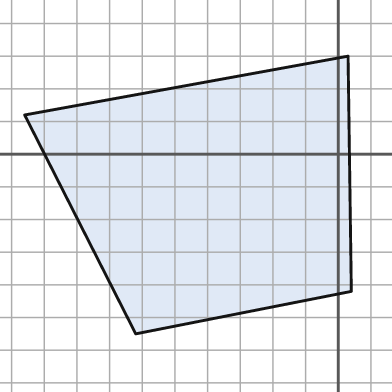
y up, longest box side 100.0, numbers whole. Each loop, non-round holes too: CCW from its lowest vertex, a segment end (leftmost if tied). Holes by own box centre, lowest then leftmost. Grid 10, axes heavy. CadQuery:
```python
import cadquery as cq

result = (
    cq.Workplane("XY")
    .moveTo(-62.0, -55.0)
    .lineTo(4.0, -42.0)
    .lineTo(3.0, 30.0)
    .lineTo(-96.0, 12.0)
    .close()
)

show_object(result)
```